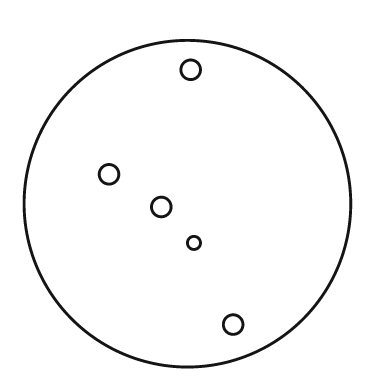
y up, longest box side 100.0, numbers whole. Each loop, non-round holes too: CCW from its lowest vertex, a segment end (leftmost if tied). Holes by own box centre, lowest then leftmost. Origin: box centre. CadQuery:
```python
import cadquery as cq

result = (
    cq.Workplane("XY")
    .moveTo(0.0, 0.0)
    .circle(50.0)
    .moveTo(14.0, -37.0)
    .circle(3.0)
    .moveTo(2.0, -12.0)
    .circle(2.0)
    .moveTo(-8.0, -1.0)
    .circle(3.0)
    .moveTo(-24.0, 9.0)
    .circle(3.0)
    .moveTo(1.0, 41.0)
    .circle(3.0)
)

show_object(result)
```